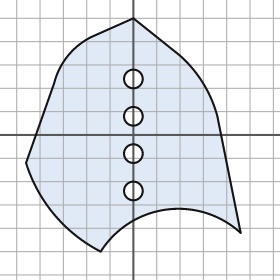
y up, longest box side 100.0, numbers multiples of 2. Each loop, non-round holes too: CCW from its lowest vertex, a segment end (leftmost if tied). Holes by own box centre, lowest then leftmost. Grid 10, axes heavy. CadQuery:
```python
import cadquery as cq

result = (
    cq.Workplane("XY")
    .moveTo(-14.0, -50.0)
    .threePointArc((14.0, -32.0), (46.0, -42.0))
    .lineTo(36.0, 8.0)
    .threePointArc((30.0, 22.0), (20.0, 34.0))
    .lineTo(0.0, 50.0)
    .lineTo(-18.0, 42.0)
    .threePointArc((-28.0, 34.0), (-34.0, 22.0))
    .lineTo(-46.0, -12.0)
    .threePointArc((-34.0, -34.0), (-14.0, -50.0))
    .close()
    .moveTo(0.0, -24.0)
    .circle(4.0)
    .moveTo(0.0, -8.0)
    .circle(4.0)
    .moveTo(0.0, 8.0)
    .circle(4.0)
    .moveTo(0.0, 24.0)
    .circle(4.0)
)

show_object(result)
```